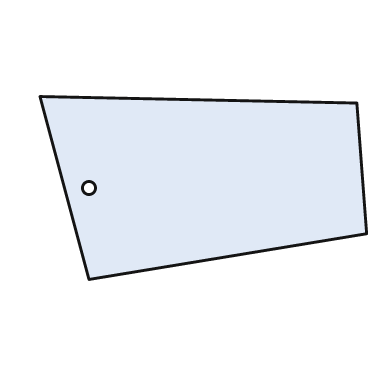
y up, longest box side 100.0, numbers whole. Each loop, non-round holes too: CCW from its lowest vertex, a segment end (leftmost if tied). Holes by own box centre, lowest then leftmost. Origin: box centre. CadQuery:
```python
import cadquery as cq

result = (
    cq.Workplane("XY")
    .moveTo(-35.0, -28.0)
    .lineTo(50.0, -14.0)
    .lineTo(47.0, 26.0)
    .lineTo(-50.0, 28.0)
    .close()
    .moveTo(-35.0, 0.0)
    .circle(2.0)
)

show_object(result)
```